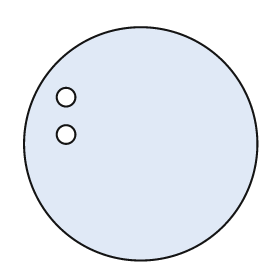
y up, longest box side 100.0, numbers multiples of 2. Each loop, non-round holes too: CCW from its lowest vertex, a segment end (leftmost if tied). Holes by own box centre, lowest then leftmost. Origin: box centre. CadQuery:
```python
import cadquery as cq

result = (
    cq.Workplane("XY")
    .moveTo(0.0, 0.0)
    .circle(50.0)
    .moveTo(-32.0, 4.0)
    .circle(4.0)
    .moveTo(-32.0, 20.0)
    .circle(4.0)
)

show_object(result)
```